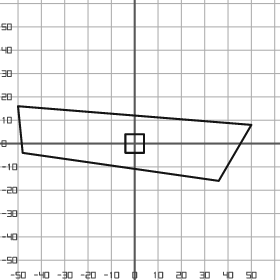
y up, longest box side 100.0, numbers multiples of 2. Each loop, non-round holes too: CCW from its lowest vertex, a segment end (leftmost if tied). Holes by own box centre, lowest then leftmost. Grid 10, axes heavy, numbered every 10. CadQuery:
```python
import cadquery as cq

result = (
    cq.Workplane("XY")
    .moveTo(36.0, -16.0)
    .lineTo(50.0, 8.0)
    .lineTo(-50.0, 16.0)
    .lineTo(-48.0, -4.0)
    .close()
    .moveTo(-4.0, -4.0)
    .lineTo(4.0, -4.0)
    .lineTo(4.0, 4.0)
    .lineTo(-4.0, 4.0)
    .close()
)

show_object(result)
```